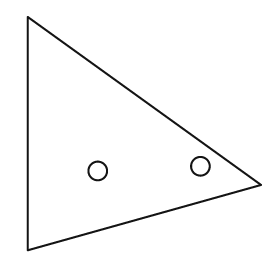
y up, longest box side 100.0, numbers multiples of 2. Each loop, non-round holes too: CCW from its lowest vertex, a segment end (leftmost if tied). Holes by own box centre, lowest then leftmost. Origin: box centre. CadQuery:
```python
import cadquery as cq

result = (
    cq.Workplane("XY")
    .moveTo(-50.0, -50.0)
    .lineTo(50.0, -22.0)
    .lineTo(-50.0, 50.0)
    .close()
    .moveTo(-20.0, -16.0)
    .circle(4.0)
    .moveTo(24.0, -14.0)
    .circle(4.0)
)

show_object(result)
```